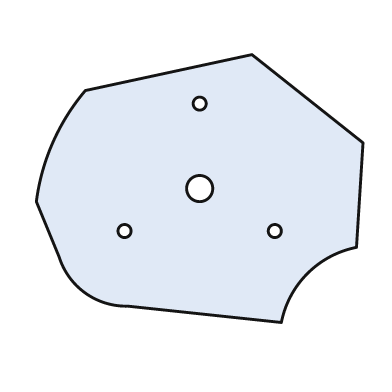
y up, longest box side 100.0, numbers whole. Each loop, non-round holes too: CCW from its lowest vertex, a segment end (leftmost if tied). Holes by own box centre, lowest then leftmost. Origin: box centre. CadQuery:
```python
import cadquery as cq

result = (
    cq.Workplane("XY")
    .moveTo(25.0, -41.0)
    .threePointArc((33.0, -26.0), (48.0, -18.0))
    .lineTo(50.0, 14.0)
    .lineTo(16.0, 41.0)
    .lineTo(-35.0, 30.0)
    .threePointArc((-45.0, 14.0), (-50.0, -4.0))
    .lineTo(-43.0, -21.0)
    .threePointArc((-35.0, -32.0), (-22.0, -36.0))
    .close()
    .moveTo(-23.0, -13.0)
    .circle(2.0)
    .moveTo(23.0, -13.0)
    .circle(2.0)
    .moveTo(0.0, 0.0)
    .circle(4.0)
    .moveTo(0.0, 26.0)
    .circle(2.0)
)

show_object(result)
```